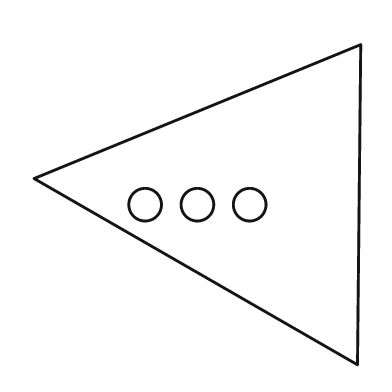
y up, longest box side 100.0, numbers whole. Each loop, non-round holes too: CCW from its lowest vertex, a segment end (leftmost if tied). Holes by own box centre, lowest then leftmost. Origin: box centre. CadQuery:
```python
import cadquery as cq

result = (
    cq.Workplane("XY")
    .moveTo(49.0, -49.0)
    .lineTo(50.0, 49.0)
    .lineTo(-50.0, 8.0)
    .close()
    .moveTo(-16.0, 0.0)
    .circle(5.0)
    .moveTo(0.0, 0.0)
    .circle(5.0)
    .moveTo(16.0, 0.0)
    .circle(5.0)
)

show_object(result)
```